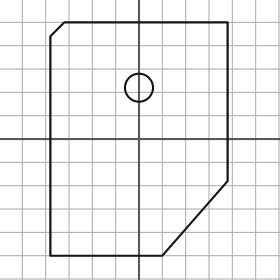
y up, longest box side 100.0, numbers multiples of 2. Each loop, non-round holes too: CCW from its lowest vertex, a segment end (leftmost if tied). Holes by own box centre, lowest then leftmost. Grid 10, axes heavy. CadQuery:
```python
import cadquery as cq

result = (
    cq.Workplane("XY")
    .moveTo(-38.0, -50.0)
    .lineTo(10.0, -50.0)
    .lineTo(38.0, -18.0)
    .lineTo(38.0, 50.0)
    .lineTo(-32.0, 50.0)
    .lineTo(-38.0, 44.0)
    .close()
    .moveTo(0.0, 22.0)
    .circle(6.0)
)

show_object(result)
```